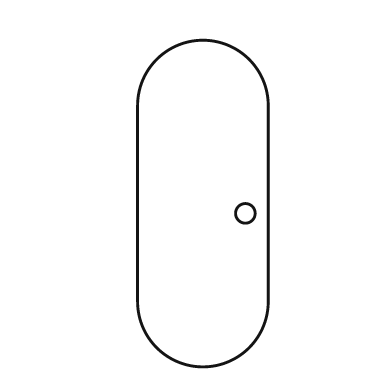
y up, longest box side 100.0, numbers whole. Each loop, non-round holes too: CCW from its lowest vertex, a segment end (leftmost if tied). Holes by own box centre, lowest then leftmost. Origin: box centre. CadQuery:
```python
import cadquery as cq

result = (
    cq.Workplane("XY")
    .moveTo(-20.0, -30.0)
    .threePointArc((0.0, -50.0), (20.0, -30.0))
    .lineTo(20.0, 30.0)
    .threePointArc((0.0, 50.0), (-20.0, 30.0))
    .close()
    .moveTo(13.0, -3.0)
    .circle(3.0)
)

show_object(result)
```